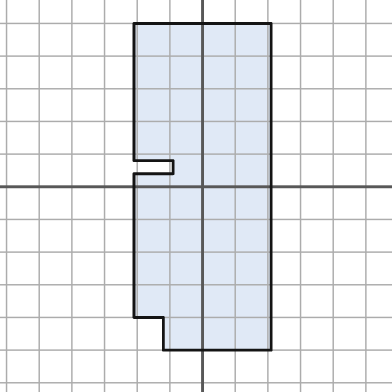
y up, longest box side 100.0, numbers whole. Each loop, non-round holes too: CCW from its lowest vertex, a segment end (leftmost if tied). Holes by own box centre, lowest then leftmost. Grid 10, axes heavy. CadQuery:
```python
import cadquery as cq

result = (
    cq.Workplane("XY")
    .moveTo(-12.0, -50.0)
    .lineTo(21.0, -50.0)
    .lineTo(21.0, 50.0)
    .lineTo(-21.0, 50.0)
    .lineTo(-21.0, 8.0)
    .lineTo(-9.0, 8.0)
    .lineTo(-9.0, 4.0)
    .lineTo(-21.0, 4.0)
    .lineTo(-21.0, -40.0)
    .lineTo(-12.0, -40.0)
    .close()
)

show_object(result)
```